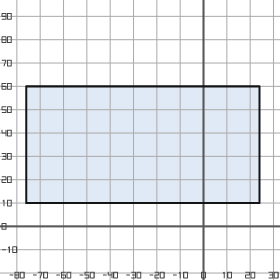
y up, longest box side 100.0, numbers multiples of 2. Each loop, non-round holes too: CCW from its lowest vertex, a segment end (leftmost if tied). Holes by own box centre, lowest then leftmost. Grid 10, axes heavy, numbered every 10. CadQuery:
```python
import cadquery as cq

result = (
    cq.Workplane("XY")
    .moveTo(-76.0, 10.0)
    .lineTo(24.0, 10.0)
    .lineTo(24.0, 60.0)
    .lineTo(-76.0, 60.0)
    .close()
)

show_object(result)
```